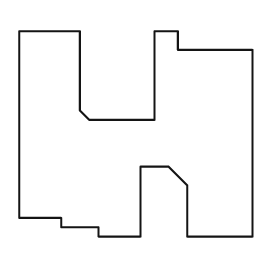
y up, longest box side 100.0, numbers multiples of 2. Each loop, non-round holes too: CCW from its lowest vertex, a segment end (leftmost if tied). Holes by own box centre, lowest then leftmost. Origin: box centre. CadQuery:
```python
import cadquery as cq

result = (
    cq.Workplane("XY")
    .moveTo(-16.0, -44.0)
    .lineTo(2.0, -44.0)
    .lineTo(2.0, -14.0)
    .lineTo(14.0, -14.0)
    .lineTo(22.0, -22.0)
    .lineTo(22.0, -44.0)
    .lineTo(50.0, -44.0)
    .lineTo(50.0, 36.0)
    .lineTo(18.0, 36.0)
    .lineTo(18.0, 44.0)
    .lineTo(8.0, 44.0)
    .lineTo(8.0, 6.0)
    .lineTo(-20.0, 6.0)
    .lineTo(-24.0, 10.0)
    .lineTo(-24.0, 44.0)
    .lineTo(-50.0, 44.0)
    .lineTo(-50.0, -36.0)
    .lineTo(-32.0, -36.0)
    .lineTo(-32.0, -40.0)
    .lineTo(-16.0, -40.0)
    .close()
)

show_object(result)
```